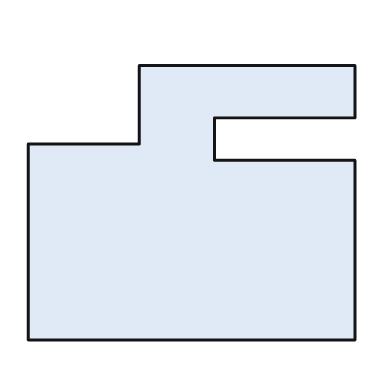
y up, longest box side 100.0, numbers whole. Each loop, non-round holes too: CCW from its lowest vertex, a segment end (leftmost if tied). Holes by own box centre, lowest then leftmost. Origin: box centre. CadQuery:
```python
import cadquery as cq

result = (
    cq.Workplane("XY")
    .moveTo(-50.0, -42.0)
    .lineTo(50.0, -42.0)
    .lineTo(50.0, 13.0)
    .lineTo(7.0, 13.0)
    .lineTo(7.0, 26.0)
    .lineTo(50.0, 26.0)
    .lineTo(50.0, 42.0)
    .lineTo(-16.0, 42.0)
    .lineTo(-16.0, 18.0)
    .lineTo(-50.0, 18.0)
    .close()
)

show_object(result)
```